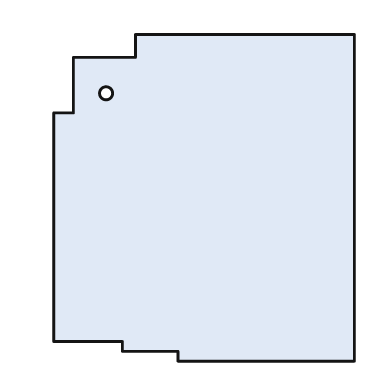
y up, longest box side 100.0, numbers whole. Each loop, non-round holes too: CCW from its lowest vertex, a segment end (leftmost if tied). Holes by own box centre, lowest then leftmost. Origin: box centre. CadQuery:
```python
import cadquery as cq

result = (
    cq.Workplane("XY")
    .moveTo(-8.0, -50.0)
    .lineTo(46.0, -50.0)
    .lineTo(46.0, 50.0)
    .lineTo(-21.0, 50.0)
    .lineTo(-21.0, 43.0)
    .lineTo(-40.0, 43.0)
    .lineTo(-40.0, 26.0)
    .lineTo(-46.0, 26.0)
    .lineTo(-46.0, -44.0)
    .lineTo(-25.0, -44.0)
    .lineTo(-25.0, -47.0)
    .lineTo(-8.0, -47.0)
    .close()
    .moveTo(-30.0, 32.0)
    .circle(2.0)
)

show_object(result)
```